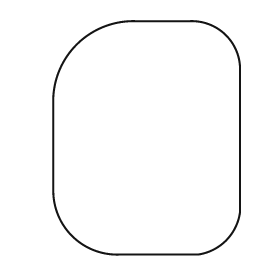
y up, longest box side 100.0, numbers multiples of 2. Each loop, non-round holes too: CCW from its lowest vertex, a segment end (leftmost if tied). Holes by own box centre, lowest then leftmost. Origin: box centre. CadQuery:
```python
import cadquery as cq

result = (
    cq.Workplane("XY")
    .moveTo(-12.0, -50.0)
    .lineTo(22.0, -50.0)
    .threePointArc((34.0, -44.0), (40.0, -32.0))
    .lineTo(40.0, 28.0)
    .threePointArc((34.0, 44.0), (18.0, 50.0))
    .lineTo(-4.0, 50.0)
    .threePointArc((-30.0, 40.0), (-40.0, 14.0))
    .lineTo(-40.0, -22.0)
    .threePointArc((-32.0, -42.0), (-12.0, -50.0))
    .close()
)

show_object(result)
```